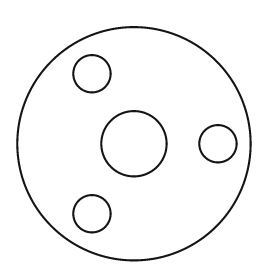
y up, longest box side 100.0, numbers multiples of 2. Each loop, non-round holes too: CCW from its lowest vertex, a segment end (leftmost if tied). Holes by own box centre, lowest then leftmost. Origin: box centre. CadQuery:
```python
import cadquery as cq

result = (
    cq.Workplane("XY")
    .moveTo(0.0, 0.0)
    .circle(50.0)
    .moveTo(-18.0, -30.0)
    .circle(8.0)
    .moveTo(0.0, 0.0)
    .circle(14.0)
    .moveTo(36.0, 0.0)
    .circle(8.0)
    .moveTo(-18.0, 30.0)
    .circle(8.0)
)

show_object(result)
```